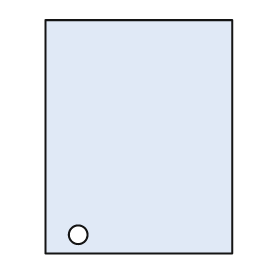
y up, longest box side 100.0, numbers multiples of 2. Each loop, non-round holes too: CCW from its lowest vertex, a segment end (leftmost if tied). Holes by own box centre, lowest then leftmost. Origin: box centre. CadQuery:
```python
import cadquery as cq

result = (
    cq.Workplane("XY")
    .moveTo(-40.0, -50.0)
    .lineTo(40.0, -50.0)
    .lineTo(40.0, 50.0)
    .lineTo(-40.0, 50.0)
    .close()
    .moveTo(-26.0, -42.0)
    .circle(4.0)
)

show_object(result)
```